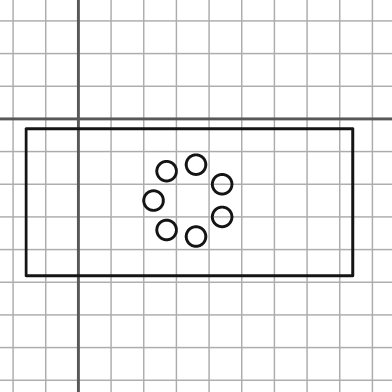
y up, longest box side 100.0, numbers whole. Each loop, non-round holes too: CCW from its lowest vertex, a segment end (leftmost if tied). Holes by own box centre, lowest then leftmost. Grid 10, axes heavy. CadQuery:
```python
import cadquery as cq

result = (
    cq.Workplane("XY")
    .moveTo(-16.0, -48.0)
    .lineTo(84.0, -48.0)
    .lineTo(84.0, -3.0)
    .lineTo(-16.0, -3.0)
    .close()
    .moveTo(36.0, -36.0)
    .circle(3.0)
    .moveTo(27.0, -34.0)
    .circle(3.0)
    .moveTo(44.0, -30.0)
    .circle(3.0)
    .moveTo(23.0, -25.0)
    .circle(3.0)
    .moveTo(44.0, -20.0)
    .circle(3.0)
    .moveTo(27.0, -16.0)
    .circle(3.0)
    .moveTo(36.0, -14.0)
    .circle(3.0)
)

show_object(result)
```